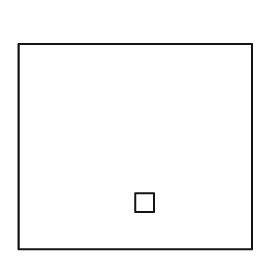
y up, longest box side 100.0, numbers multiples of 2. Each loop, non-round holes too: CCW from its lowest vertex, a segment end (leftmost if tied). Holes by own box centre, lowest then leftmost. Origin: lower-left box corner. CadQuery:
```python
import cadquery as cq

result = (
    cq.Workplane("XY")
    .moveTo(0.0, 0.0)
    .lineTo(100.0, 0.0)
    .lineTo(100.0, 88.0)
    .lineTo(0.0, 88.0)
    .close()
    .moveTo(50.0, 16.0)
    .lineTo(58.0, 16.0)
    .lineTo(58.0, 24.0)
    .lineTo(50.0, 24.0)
    .close()
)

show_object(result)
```